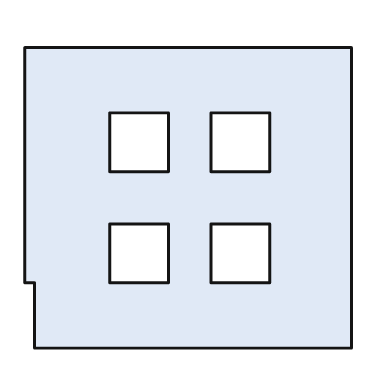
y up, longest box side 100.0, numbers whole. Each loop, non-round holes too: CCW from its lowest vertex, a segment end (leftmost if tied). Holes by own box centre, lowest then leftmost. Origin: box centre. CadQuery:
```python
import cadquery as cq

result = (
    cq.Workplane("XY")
    .moveTo(-47.0, -46.0)
    .lineTo(50.0, -46.0)
    .lineTo(50.0, 46.0)
    .lineTo(-50.0, 46.0)
    .lineTo(-50.0, -26.0)
    .lineTo(-47.0, -26.0)
    .close()
    .moveTo(-24.0, -26.0)
    .lineTo(-6.0, -26.0)
    .lineTo(-6.0, -8.0)
    .lineTo(-24.0, -8.0)
    .close()
    .moveTo(7.0, -26.0)
    .lineTo(25.0, -26.0)
    .lineTo(25.0, -8.0)
    .lineTo(7.0, -8.0)
    .close()
    .moveTo(-24.0, 8.0)
    .lineTo(-6.0, 8.0)
    .lineTo(-6.0, 26.0)
    .lineTo(-24.0, 26.0)
    .close()
    .moveTo(7.0, 8.0)
    .lineTo(25.0, 8.0)
    .lineTo(25.0, 26.0)
    .lineTo(7.0, 26.0)
    .close()
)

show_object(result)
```